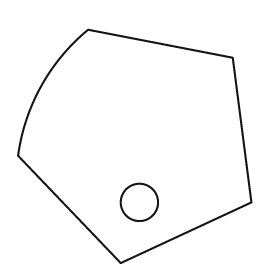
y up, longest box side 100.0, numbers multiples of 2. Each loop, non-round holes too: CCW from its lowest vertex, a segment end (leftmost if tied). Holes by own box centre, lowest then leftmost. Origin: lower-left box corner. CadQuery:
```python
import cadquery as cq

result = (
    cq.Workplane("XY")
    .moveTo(44.0, 0.0)
    .lineTo(100.0, 26.0)
    .lineTo(92.0, 88.0)
    .lineTo(30.0, 100.0)
    .threePointArc((10.0, 76.0), (0.0, 46.0))
    .close()
    .moveTo(52.0, 26.0)
    .circle(8.0)
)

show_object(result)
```